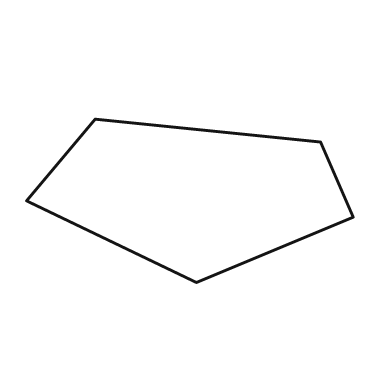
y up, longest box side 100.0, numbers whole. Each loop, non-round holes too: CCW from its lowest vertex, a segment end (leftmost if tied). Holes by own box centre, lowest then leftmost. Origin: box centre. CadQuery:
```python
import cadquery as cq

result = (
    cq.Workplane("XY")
    .moveTo(2.0, -25.0)
    .lineTo(50.0, -5.0)
    .lineTo(40.0, 18.0)
    .lineTo(-29.0, 25.0)
    .lineTo(-50.0, 0.0)
    .close()
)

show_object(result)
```